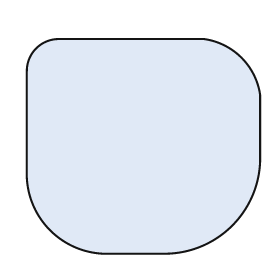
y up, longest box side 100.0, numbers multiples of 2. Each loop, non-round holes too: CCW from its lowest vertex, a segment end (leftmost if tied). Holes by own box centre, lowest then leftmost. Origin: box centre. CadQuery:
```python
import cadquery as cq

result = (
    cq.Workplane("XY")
    .moveTo(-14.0, -46.0)
    .lineTo(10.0, -46.0)
    .threePointArc((38.0, -34.0), (50.0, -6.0))
    .lineTo(50.0, 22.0)
    .threePointArc((42.0, 38.0), (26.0, 46.0))
    .lineTo(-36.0, 46.0)
    .threePointArc((-46.0, 42.0), (-50.0, 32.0))
    .lineTo(-50.0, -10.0)
    .threePointArc((-40.0, -36.0), (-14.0, -46.0))
    .close()
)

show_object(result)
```